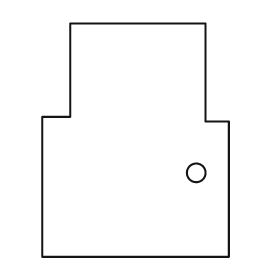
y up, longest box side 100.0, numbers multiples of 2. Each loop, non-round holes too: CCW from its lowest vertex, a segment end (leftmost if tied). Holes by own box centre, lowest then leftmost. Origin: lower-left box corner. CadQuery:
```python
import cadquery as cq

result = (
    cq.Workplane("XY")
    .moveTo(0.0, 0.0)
    .lineTo(80.0, 0.0)
    .lineTo(80.0, 58.0)
    .lineTo(70.0, 58.0)
    .lineTo(70.0, 100.0)
    .lineTo(12.0, 100.0)
    .lineTo(12.0, 60.0)
    .lineTo(0.0, 60.0)
    .close()
    .moveTo(66.0, 36.0)
    .circle(4.0)
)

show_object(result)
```